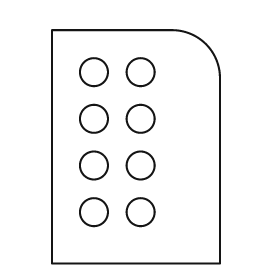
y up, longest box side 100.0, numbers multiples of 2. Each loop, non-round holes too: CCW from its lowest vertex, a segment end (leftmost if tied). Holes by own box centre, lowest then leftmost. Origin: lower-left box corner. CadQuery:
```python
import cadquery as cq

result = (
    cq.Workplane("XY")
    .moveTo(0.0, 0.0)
    .lineTo(72.0, 0.0)
    .lineTo(72.0, 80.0)
    .threePointArc((66.0, 94.0), (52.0, 100.0))
    .lineTo(0.0, 100.0)
    .close()
    .moveTo(18.0, 22.0)
    .circle(6.0)
    .moveTo(38.0, 22.0)
    .circle(6.0)
    .moveTo(18.0, 42.0)
    .circle(6.0)
    .moveTo(38.0, 42.0)
    .circle(6.0)
    .moveTo(18.0, 62.0)
    .circle(6.0)
    .moveTo(38.0, 62.0)
    .circle(6.0)
    .moveTo(18.0, 82.0)
    .circle(6.0)
    .moveTo(38.0, 82.0)
    .circle(6.0)
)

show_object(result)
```